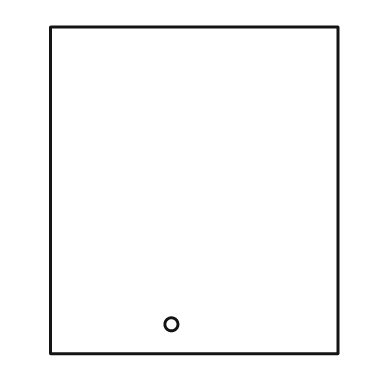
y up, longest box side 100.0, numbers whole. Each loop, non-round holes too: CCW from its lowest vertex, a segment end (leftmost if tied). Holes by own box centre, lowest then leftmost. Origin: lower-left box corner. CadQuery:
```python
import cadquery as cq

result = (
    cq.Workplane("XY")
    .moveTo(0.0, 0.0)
    .lineTo(88.0, 0.0)
    .lineTo(88.0, 100.0)
    .lineTo(0.0, 100.0)
    .close()
    .moveTo(37.0, 9.0)
    .circle(2.0)
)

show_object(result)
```